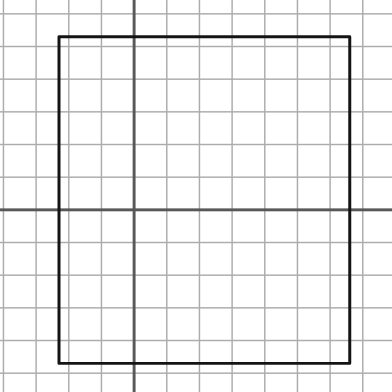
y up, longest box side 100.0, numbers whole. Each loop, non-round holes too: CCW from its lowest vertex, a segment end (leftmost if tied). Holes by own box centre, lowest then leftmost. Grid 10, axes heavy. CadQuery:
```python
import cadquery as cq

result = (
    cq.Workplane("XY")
    .moveTo(-23.0, -47.0)
    .lineTo(66.0, -47.0)
    .lineTo(66.0, 53.0)
    .lineTo(-23.0, 53.0)
    .close()
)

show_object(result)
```